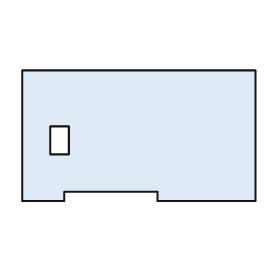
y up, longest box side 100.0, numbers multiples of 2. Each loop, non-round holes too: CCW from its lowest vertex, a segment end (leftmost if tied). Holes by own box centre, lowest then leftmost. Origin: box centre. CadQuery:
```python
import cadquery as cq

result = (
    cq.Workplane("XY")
    .moveTo(-50.0, -28.0)
    .lineTo(-32.0, -28.0)
    .lineTo(-32.0, -24.0)
    .lineTo(8.0, -24.0)
    .lineTo(8.0, -28.0)
    .lineTo(50.0, -28.0)
    .lineTo(50.0, 28.0)
    .lineTo(-50.0, 28.0)
    .close()
    .moveTo(-38.0, -8.0)
    .lineTo(-30.0, -8.0)
    .lineTo(-30.0, 4.0)
    .lineTo(-38.0, 4.0)
    .close()
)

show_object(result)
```